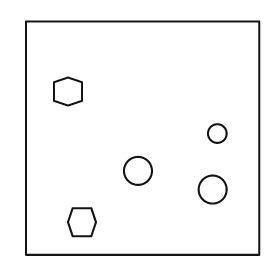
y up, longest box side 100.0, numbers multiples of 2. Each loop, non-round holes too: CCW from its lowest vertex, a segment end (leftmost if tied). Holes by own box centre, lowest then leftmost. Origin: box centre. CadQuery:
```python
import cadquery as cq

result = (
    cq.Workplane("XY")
    .moveTo(-50.0, -50.0)
    .lineTo(50.0, -50.0)
    .lineTo(50.0, 50.0)
    .lineTo(-50.0, 50.0)
    .close()
    .moveTo(-30.0, -42.0)
    .lineTo(-22.0, -42.0)
    .lineTo(-20.0, -36.0)
    .lineTo(-22.0, -30.0)
    .lineTo(-30.0, -30.0)
    .lineTo(-32.0, -36.0)
    .close()
    .moveTo(30.0, -22.0)
    .circle(6.0)
    .moveTo(-2.0, -14.0)
    .circle(6.0)
    .moveTo(32.0, 2.0)
    .circle(4.0)
    .moveTo(-32.0, 14.0)
    .lineTo(-26.0, 16.0)
    .lineTo(-26.0, 24.0)
    .lineTo(-32.0, 26.0)
    .lineTo(-38.0, 24.0)
    .lineTo(-38.0, 16.0)
    .close()
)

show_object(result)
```